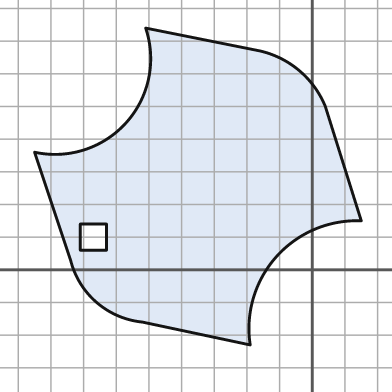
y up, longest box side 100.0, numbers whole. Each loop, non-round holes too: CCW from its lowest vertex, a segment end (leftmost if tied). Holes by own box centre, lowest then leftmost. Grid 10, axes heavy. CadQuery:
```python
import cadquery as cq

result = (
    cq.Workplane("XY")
    .moveTo(-19.0, -23.0)
    .threePointArc((-11.0, 4.0), (15.0, 15.0))
    .lineTo(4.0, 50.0)
    .threePointArc((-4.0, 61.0), (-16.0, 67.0))
    .lineTo(-51.0, 74.0)
    .threePointArc((-57.0, 45.0), (-85.0, 36.0))
    .lineTo(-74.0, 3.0)
    .threePointArc((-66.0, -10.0), (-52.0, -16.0))
    .close()
    .moveTo(-71.0, 6.0)
    .lineTo(-63.0, 6.0)
    .lineTo(-63.0, 14.0)
    .lineTo(-71.0, 14.0)
    .close()
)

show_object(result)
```